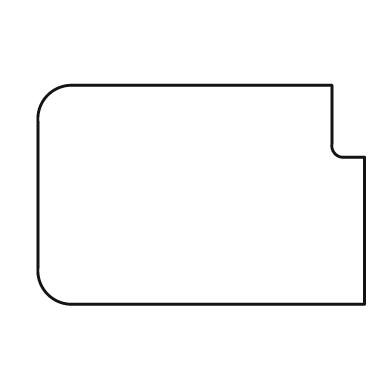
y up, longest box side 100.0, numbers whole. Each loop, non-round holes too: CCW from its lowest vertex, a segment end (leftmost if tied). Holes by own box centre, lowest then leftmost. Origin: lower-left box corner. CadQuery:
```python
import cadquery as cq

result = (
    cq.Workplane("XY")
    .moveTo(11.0, 0.0)
    .lineTo(100.0, 0.0)
    .lineTo(100.0, 45.0)
    .lineTo(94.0, 45.0)
    .threePointArc((91.0, 46.0), (90.0, 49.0))
    .lineTo(90.0, 67.0)
    .lineTo(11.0, 67.0)
    .threePointArc((3.0, 64.0), (0.0, 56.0))
    .lineTo(0.0, 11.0)
    .threePointArc((3.0, 3.0), (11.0, 0.0))
    .close()
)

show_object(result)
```